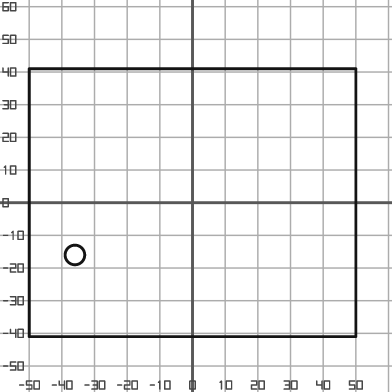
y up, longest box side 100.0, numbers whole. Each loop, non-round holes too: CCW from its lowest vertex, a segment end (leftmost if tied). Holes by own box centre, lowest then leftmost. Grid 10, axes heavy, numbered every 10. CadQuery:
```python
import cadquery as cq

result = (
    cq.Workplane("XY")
    .moveTo(-50.0, -41.0)
    .lineTo(50.0, -41.0)
    .lineTo(50.0, 41.0)
    .lineTo(-50.0, 41.0)
    .close()
    .moveTo(-36.0, -16.0)
    .circle(3.0)
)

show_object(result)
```